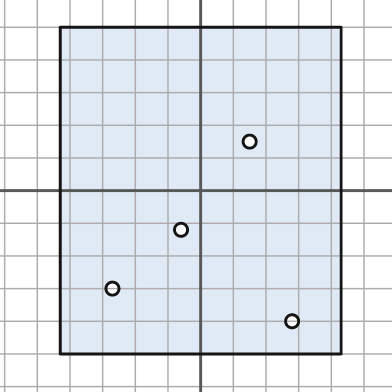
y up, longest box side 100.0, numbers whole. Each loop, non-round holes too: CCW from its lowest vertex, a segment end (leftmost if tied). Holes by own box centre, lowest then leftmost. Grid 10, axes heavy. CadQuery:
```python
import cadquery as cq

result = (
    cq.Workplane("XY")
    .moveTo(-43.0, -50.0)
    .lineTo(43.0, -50.0)
    .lineTo(43.0, 50.0)
    .lineTo(-43.0, 50.0)
    .close()
    .moveTo(28.0, -40.0)
    .circle(2.0)
    .moveTo(-27.0, -30.0)
    .circle(2.0)
    .moveTo(-6.0, -12.0)
    .circle(2.0)
    .moveTo(15.0, 15.0)
    .circle(2.0)
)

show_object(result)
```